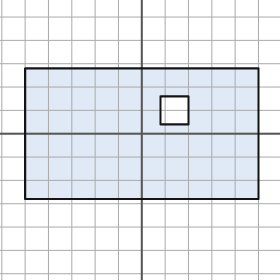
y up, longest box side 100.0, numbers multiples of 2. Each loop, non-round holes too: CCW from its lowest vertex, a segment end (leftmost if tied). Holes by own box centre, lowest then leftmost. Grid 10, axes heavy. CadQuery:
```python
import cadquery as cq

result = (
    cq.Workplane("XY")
    .moveTo(-50.0, -28.0)
    .lineTo(50.0, -28.0)
    .lineTo(50.0, 28.0)
    .lineTo(-50.0, 28.0)
    .close()
    .moveTo(8.0, 4.0)
    .lineTo(20.0, 4.0)
    .lineTo(20.0, 16.0)
    .lineTo(8.0, 16.0)
    .close()
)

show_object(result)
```